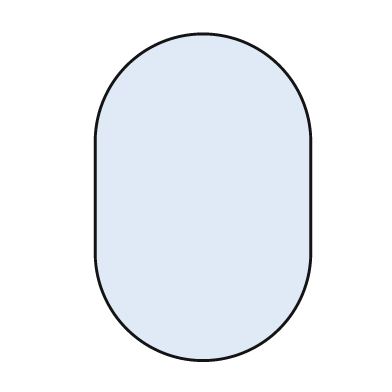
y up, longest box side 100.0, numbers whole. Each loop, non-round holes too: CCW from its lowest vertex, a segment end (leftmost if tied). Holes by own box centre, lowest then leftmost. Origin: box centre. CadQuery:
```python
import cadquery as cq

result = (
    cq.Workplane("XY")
    .moveTo(-33.0, -17.0)
    .threePointArc((0.0, -50.0), (33.0, -17.0))
    .lineTo(33.0, 17.0)
    .threePointArc((0.0, 50.0), (-33.0, 17.0))
    .close()
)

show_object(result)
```